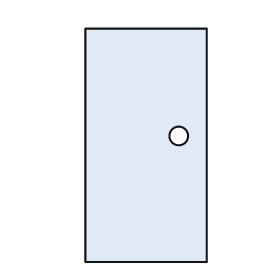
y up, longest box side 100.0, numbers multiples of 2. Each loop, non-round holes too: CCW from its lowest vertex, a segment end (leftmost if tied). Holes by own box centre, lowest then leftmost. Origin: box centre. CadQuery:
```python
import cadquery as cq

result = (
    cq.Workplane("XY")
    .moveTo(-26.0, -50.0)
    .lineTo(26.0, -50.0)
    .lineTo(26.0, 50.0)
    .lineTo(-26.0, 50.0)
    .close()
    .moveTo(14.0, 4.0)
    .circle(4.0)
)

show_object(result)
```